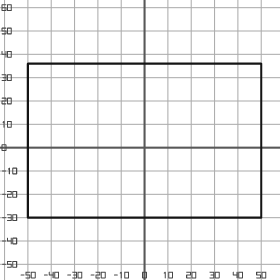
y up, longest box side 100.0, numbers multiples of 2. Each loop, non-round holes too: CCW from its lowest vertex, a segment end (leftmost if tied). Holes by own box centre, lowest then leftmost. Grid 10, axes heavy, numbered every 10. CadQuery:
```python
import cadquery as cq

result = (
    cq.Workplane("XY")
    .moveTo(-50.0, -30.0)
    .lineTo(50.0, -30.0)
    .lineTo(50.0, 36.0)
    .lineTo(-50.0, 36.0)
    .close()
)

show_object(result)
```